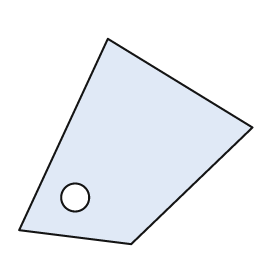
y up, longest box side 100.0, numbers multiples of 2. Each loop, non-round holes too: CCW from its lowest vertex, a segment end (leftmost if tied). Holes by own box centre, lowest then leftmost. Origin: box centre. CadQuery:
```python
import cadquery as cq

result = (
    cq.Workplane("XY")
    .moveTo(-2.0, -44.0)
    .lineTo(50.0, 6.0)
    .lineTo(-12.0, 44.0)
    .lineTo(-50.0, -38.0)
    .close()
    .moveTo(-26.0, -24.0)
    .circle(6.0)
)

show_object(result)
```